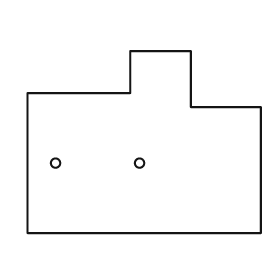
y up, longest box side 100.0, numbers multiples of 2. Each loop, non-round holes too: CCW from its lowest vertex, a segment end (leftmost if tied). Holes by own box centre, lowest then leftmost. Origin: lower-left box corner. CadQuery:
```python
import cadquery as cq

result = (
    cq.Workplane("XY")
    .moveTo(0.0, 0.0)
    .lineTo(100.0, 0.0)
    .lineTo(100.0, 54.0)
    .lineTo(70.0, 54.0)
    .lineTo(70.0, 78.0)
    .lineTo(44.0, 78.0)
    .lineTo(44.0, 60.0)
    .lineTo(0.0, 60.0)
    .close()
    .moveTo(12.0, 30.0)
    .circle(2.0)
    .moveTo(48.0, 30.0)
    .circle(2.0)
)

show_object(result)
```